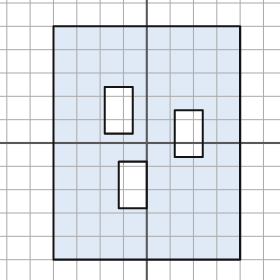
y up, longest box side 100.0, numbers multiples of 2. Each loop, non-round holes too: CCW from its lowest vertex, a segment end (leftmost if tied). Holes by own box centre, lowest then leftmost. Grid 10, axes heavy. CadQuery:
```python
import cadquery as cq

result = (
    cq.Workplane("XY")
    .moveTo(-40.0, -50.0)
    .lineTo(40.0, -50.0)
    .lineTo(40.0, 50.0)
    .lineTo(-40.0, 50.0)
    .close()
    .moveTo(-12.0, -28.0)
    .lineTo(0.0, -28.0)
    .lineTo(0.0, -8.0)
    .lineTo(-12.0, -8.0)
    .close()
    .moveTo(12.0, -6.0)
    .lineTo(24.0, -6.0)
    .lineTo(24.0, 14.0)
    .lineTo(12.0, 14.0)
    .close()
    .moveTo(-18.0, 4.0)
    .lineTo(-6.0, 4.0)
    .lineTo(-6.0, 24.0)
    .lineTo(-18.0, 24.0)
    .close()
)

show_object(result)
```